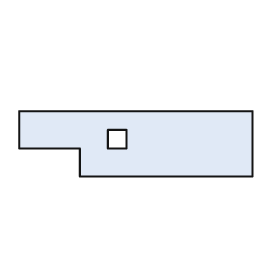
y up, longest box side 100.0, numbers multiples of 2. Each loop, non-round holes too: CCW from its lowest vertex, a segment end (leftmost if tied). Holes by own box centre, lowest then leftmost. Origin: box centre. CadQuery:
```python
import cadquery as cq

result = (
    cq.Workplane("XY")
    .moveTo(-24.0, -14.0)
    .lineTo(50.0, -14.0)
    .lineTo(50.0, 14.0)
    .lineTo(-50.0, 14.0)
    .lineTo(-50.0, -2.0)
    .lineTo(-24.0, -2.0)
    .close()
    .moveTo(-12.0, -2.0)
    .lineTo(-4.0, -2.0)
    .lineTo(-4.0, 6.0)
    .lineTo(-12.0, 6.0)
    .close()
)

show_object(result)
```